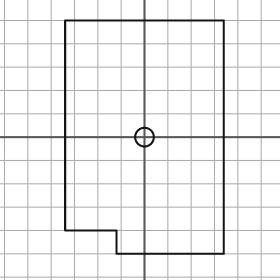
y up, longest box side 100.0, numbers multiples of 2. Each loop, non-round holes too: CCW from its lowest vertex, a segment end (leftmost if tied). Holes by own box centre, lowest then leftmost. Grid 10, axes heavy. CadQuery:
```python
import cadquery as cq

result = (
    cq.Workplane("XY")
    .moveTo(-12.0, -50.0)
    .lineTo(34.0, -50.0)
    .lineTo(34.0, 50.0)
    .lineTo(-34.0, 50.0)
    .lineTo(-34.0, -40.0)
    .lineTo(-12.0, -40.0)
    .close()
    .moveTo(0.0, 0.0)
    .circle(4.0)
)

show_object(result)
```